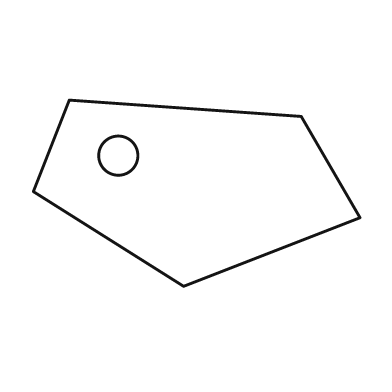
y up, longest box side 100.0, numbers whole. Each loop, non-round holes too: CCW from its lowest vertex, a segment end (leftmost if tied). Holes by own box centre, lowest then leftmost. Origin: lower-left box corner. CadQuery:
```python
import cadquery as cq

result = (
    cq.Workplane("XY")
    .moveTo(46.0, 0.0)
    .lineTo(100.0, 21.0)
    .lineTo(82.0, 52.0)
    .lineTo(11.0, 57.0)
    .lineTo(0.0, 29.0)
    .close()
    .moveTo(26.0, 40.0)
    .circle(6.0)
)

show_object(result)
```